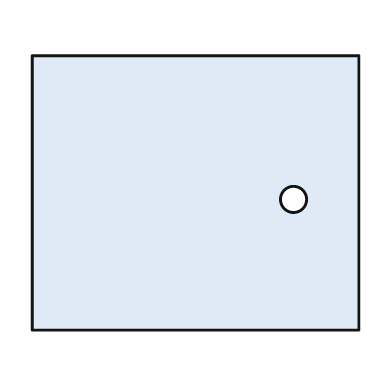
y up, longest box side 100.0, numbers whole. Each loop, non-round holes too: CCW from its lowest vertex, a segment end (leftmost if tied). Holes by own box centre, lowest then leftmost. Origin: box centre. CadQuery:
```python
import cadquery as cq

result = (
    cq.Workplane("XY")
    .moveTo(-50.0, -42.0)
    .lineTo(50.0, -42.0)
    .lineTo(50.0, 42.0)
    .lineTo(-50.0, 42.0)
    .close()
    .moveTo(30.0, -2.0)
    .circle(4.0)
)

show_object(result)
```